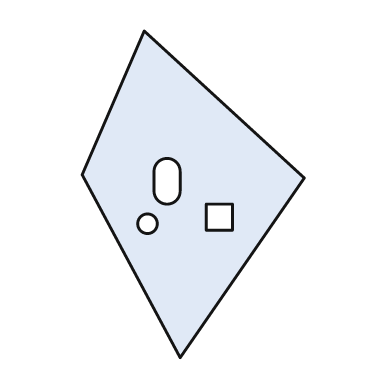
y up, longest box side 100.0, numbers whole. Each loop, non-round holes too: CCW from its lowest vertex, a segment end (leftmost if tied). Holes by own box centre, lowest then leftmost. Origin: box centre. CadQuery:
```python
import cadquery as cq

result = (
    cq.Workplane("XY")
    .moveTo(-4.0, -50.0)
    .lineTo(34.0, 5.0)
    .lineTo(-15.0, 50.0)
    .lineTo(-34.0, 6.0)
    .close()
    .moveTo(-14.0, -9.0)
    .circle(3.0)
    .moveTo(4.0, -11.0)
    .lineTo(12.0, -11.0)
    .lineTo(12.0, -3.0)
    .lineTo(4.0, -3.0)
    .close()
    .moveTo(-12.0, 1.0)
    .threePointArc((-8.0, -3.0), (-4.0, 1.0))
    .lineTo(-4.0, 7.0)
    .threePointArc((-8.0, 11.0), (-12.0, 7.0))
    .close()
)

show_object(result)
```